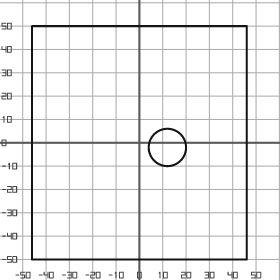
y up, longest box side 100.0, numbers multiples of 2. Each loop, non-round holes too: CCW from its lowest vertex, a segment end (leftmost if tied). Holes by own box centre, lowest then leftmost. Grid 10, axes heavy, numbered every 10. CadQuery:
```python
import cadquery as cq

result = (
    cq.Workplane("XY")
    .moveTo(-46.0, -50.0)
    .lineTo(46.0, -50.0)
    .lineTo(46.0, 50.0)
    .lineTo(-46.0, 50.0)
    .close()
    .moveTo(12.0, -2.0)
    .circle(8.0)
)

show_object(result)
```